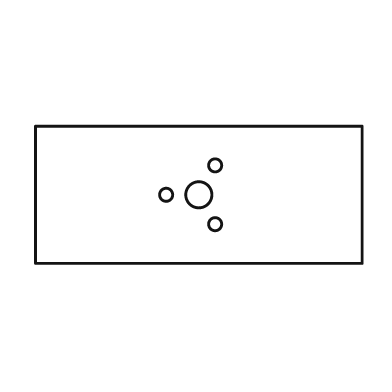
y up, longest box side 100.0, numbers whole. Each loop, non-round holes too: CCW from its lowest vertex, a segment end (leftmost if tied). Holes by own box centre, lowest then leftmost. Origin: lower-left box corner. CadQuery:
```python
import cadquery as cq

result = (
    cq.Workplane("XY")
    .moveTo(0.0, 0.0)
    .lineTo(100.0, 0.0)
    .lineTo(100.0, 42.0)
    .lineTo(0.0, 42.0)
    .close()
    .moveTo(55.0, 12.0)
    .circle(2.0)
    .moveTo(40.0, 21.0)
    .circle(2.0)
    .moveTo(50.0, 21.0)
    .circle(4.0)
    .moveTo(55.0, 30.0)
    .circle(2.0)
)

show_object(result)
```